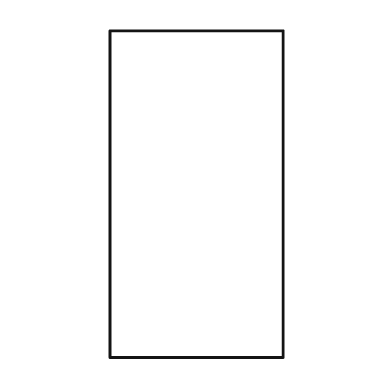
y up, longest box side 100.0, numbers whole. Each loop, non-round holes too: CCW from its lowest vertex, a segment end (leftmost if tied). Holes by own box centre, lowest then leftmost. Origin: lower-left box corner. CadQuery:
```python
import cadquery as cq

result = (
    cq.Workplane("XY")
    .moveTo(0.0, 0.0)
    .lineTo(53.0, 0.0)
    .lineTo(53.0, 100.0)
    .lineTo(0.0, 100.0)
    .close()
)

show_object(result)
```